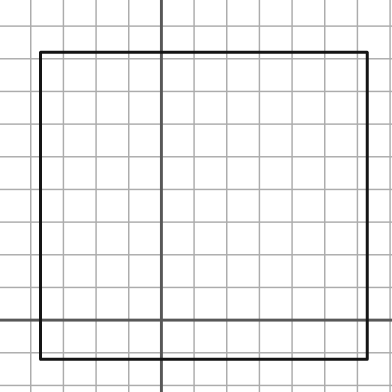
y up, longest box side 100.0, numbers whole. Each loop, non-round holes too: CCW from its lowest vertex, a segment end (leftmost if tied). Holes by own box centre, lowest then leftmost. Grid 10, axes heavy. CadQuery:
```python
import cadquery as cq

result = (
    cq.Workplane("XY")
    .moveTo(-37.0, -12.0)
    .lineTo(63.0, -12.0)
    .lineTo(63.0, 82.0)
    .lineTo(-37.0, 82.0)
    .close()
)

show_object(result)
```